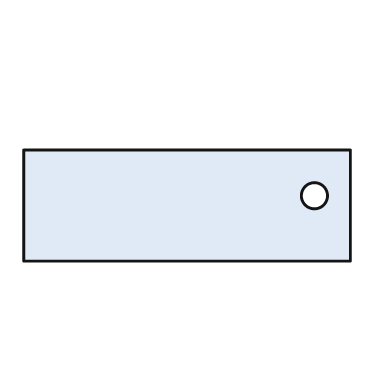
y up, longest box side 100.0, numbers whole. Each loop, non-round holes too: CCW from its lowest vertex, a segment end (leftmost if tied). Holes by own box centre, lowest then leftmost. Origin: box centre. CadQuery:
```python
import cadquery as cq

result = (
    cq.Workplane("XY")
    .moveTo(-50.0, -17.0)
    .lineTo(50.0, -17.0)
    .lineTo(50.0, 17.0)
    .lineTo(-50.0, 17.0)
    .close()
    .moveTo(39.0, 3.0)
    .circle(4.0)
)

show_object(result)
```